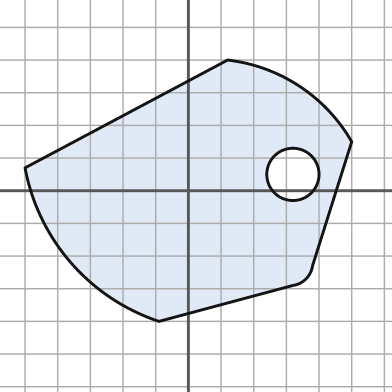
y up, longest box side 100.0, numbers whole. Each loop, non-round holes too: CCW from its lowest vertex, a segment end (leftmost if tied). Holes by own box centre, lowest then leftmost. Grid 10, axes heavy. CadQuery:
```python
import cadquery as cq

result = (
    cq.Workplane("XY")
    .moveTo(-9.0, -40.0)
    .lineTo(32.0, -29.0)
    .threePointArc((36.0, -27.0), (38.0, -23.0))
    .lineTo(50.0, 15.0)
    .threePointArc((34.0, 32.0), (12.0, 40.0))
    .lineTo(-50.0, 7.0)
    .threePointArc((-36.0, -22.0), (-9.0, -40.0))
    .close()
    .moveTo(32.0, 5.0)
    .circle(8.0)
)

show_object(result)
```